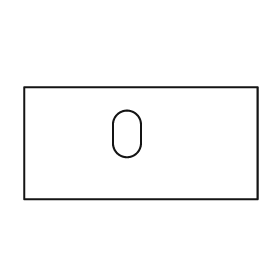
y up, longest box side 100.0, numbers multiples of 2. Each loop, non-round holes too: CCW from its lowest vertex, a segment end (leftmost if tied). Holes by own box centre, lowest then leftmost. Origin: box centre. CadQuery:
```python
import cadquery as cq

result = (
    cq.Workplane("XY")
    .moveTo(-50.0, -24.0)
    .lineTo(50.0, -24.0)
    .lineTo(50.0, 24.0)
    .lineTo(-50.0, 24.0)
    .close()
    .moveTo(-12.0, 0.0)
    .threePointArc((-6.0, -6.0), (0.0, 0.0))
    .lineTo(0.0, 8.0)
    .threePointArc((-6.0, 14.0), (-12.0, 8.0))
    .close()
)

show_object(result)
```